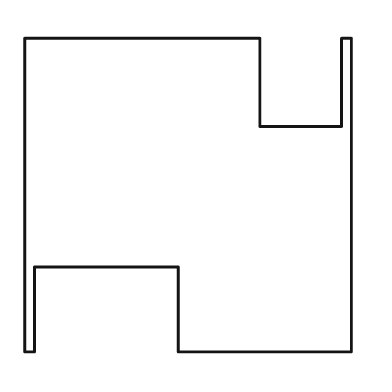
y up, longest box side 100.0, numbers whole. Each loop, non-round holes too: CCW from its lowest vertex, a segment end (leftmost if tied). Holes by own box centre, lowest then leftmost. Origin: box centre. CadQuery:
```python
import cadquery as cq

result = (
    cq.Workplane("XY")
    .moveTo(-50.0, -48.0)
    .lineTo(-47.0, -48.0)
    .lineTo(-47.0, -22.0)
    .lineTo(-3.0, -22.0)
    .lineTo(-3.0, -48.0)
    .lineTo(50.0, -48.0)
    .lineTo(50.0, 48.0)
    .lineTo(47.0, 48.0)
    .lineTo(47.0, 21.0)
    .lineTo(22.0, 21.0)
    .lineTo(22.0, 48.0)
    .lineTo(-50.0, 48.0)
    .close()
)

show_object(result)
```